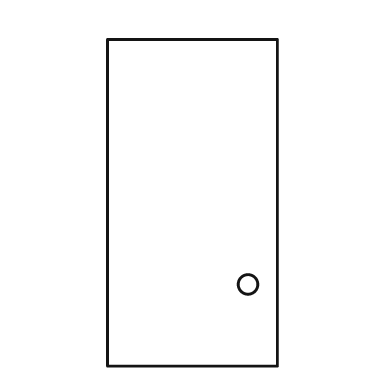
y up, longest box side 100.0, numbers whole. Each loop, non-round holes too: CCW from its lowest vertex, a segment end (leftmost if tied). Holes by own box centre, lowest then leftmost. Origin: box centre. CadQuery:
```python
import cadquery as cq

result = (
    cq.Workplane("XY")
    .moveTo(-26.0, -50.0)
    .lineTo(26.0, -50.0)
    .lineTo(26.0, 50.0)
    .lineTo(-26.0, 50.0)
    .close()
    .moveTo(17.0, -25.0)
    .circle(3.0)
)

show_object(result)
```